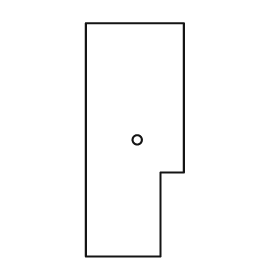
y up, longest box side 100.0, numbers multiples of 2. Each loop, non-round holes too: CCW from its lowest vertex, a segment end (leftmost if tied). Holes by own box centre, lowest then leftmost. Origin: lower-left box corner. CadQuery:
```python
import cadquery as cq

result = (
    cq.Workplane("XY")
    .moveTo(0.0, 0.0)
    .lineTo(32.0, 0.0)
    .lineTo(32.0, 36.0)
    .lineTo(42.0, 36.0)
    .lineTo(42.0, 100.0)
    .lineTo(0.0, 100.0)
    .close()
    .moveTo(22.0, 50.0)
    .circle(2.0)
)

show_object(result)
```